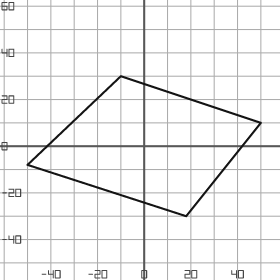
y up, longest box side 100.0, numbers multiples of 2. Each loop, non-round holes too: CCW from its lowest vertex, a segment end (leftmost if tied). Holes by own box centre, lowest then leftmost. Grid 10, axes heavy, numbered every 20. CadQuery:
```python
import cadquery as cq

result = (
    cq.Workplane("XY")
    .moveTo(18.0, -30.0)
    .lineTo(50.0, 10.0)
    .lineTo(-10.0, 30.0)
    .lineTo(-50.0, -8.0)
    .close()
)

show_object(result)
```